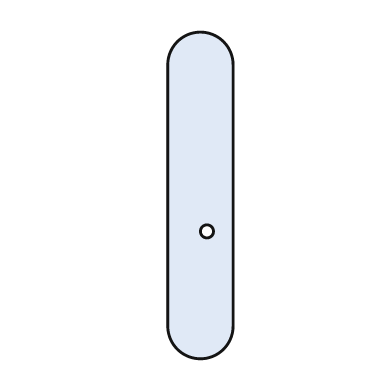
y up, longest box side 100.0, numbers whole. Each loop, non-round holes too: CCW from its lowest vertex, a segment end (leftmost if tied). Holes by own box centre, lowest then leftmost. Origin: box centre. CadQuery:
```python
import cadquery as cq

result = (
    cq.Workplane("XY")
    .moveTo(-10.0, -40.0)
    .threePointArc((0.0, -50.0), (10.0, -40.0))
    .lineTo(10.0, 40.0)
    .threePointArc((0.0, 50.0), (-10.0, 40.0))
    .close()
    .moveTo(2.0, -11.0)
    .circle(2.0)
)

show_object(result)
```